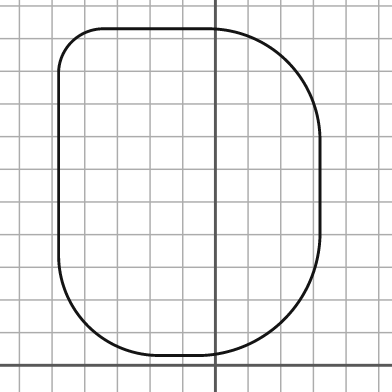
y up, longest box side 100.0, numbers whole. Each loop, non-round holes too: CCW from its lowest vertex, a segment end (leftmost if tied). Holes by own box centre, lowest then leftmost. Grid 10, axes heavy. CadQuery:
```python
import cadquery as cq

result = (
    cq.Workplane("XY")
    .moveTo(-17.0, 3.0)
    .lineTo(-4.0, 3.0)
    .threePointArc((21.0, 14.0), (32.0, 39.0))
    .lineTo(32.0, 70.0)
    .threePointArc((22.0, 93.0), (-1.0, 103.0))
    .lineTo(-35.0, 103.0)
    .threePointArc((-44.0, 99.0), (-48.0, 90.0))
    .lineTo(-48.0, 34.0)
    .threePointArc((-39.0, 12.0), (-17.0, 3.0))
    .close()
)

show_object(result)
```